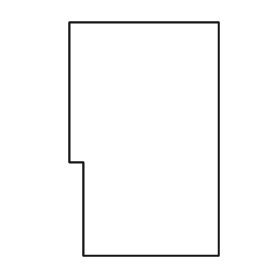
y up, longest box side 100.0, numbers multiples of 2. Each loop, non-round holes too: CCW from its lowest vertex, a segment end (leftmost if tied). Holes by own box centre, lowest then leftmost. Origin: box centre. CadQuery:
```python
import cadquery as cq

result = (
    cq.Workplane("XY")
    .moveTo(-26.0, -50.0)
    .lineTo(32.0, -50.0)
    .lineTo(32.0, 50.0)
    .lineTo(-32.0, 50.0)
    .lineTo(-32.0, -10.0)
    .lineTo(-26.0, -10.0)
    .close()
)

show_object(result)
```